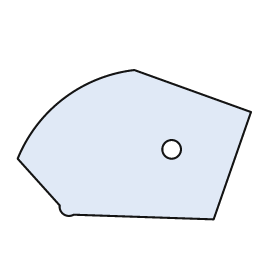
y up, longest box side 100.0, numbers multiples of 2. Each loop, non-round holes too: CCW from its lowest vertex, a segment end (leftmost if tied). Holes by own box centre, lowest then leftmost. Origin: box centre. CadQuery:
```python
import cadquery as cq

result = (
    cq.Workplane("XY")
    .moveTo(34.0, -32.0)
    .lineTo(50.0, 14.0)
    .lineTo(0.0, 32.0)
    .threePointArc((-30.0, 20.0), (-50.0, -6.0))
    .lineTo(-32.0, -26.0)
    .threePointArc((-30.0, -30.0), (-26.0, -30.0))
    .close()
    .moveTo(16.0, -2.0)
    .circle(4.0)
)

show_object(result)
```